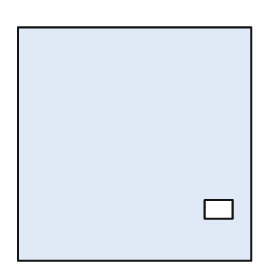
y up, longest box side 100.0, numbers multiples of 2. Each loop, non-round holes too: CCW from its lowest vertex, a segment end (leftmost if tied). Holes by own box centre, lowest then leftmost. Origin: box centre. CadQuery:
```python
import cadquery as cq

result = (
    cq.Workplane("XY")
    .moveTo(-50.0, -50.0)
    .lineTo(50.0, -50.0)
    .lineTo(50.0, 50.0)
    .lineTo(-50.0, 50.0)
    .close()
    .moveTo(30.0, -32.0)
    .lineTo(42.0, -32.0)
    .lineTo(42.0, -24.0)
    .lineTo(30.0, -24.0)
    .close()
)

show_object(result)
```